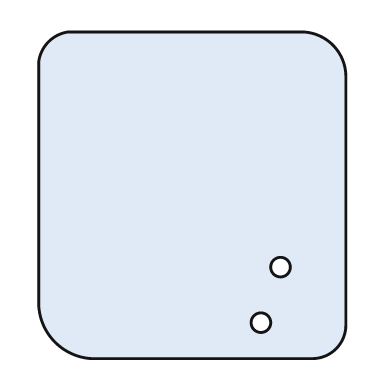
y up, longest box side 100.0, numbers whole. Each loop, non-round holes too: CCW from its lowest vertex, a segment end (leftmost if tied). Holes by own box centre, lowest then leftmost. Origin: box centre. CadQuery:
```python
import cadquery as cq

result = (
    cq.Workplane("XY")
    .moveTo(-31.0, -50.0)
    .lineTo(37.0, -50.0)
    .threePointArc((44.0, -47.0), (47.0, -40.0))
    .lineTo(47.0, 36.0)
    .threePointArc((43.0, 46.0), (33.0, 50.0))
    .lineTo(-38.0, 50.0)
    .threePointArc((-44.0, 47.0), (-47.0, 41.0))
    .lineTo(-47.0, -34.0)
    .threePointArc((-42.0, -45.0), (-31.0, -50.0))
    .close()
    .moveTo(21.0, -39.0)
    .circle(3.0)
    .moveTo(27.0, -22.0)
    .circle(3.0)
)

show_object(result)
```